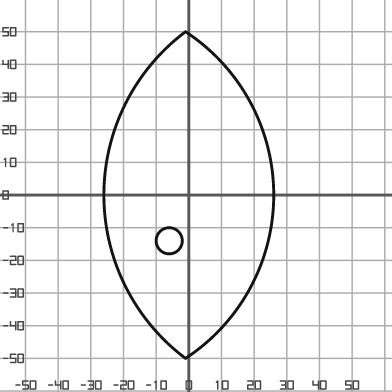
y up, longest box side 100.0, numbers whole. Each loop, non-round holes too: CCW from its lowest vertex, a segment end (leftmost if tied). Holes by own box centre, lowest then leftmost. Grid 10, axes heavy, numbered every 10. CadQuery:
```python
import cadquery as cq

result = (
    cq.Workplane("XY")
    .moveTo(-1.0, -50.0)
    .threePointArc((26.0, 0.0), (-1.0, 50.0))
    .threePointArc((-26.0, 0.0), (-1.0, -50.0))
    .close()
    .moveTo(-6.0, -14.0)
    .circle(4.0)
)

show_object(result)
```